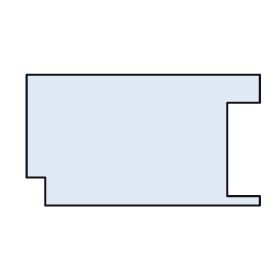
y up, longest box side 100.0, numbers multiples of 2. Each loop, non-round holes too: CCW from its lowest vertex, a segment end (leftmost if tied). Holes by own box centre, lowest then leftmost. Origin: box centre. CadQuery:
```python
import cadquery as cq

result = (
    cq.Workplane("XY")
    .moveTo(-42.0, -28.0)
    .lineTo(50.0, -28.0)
    .lineTo(50.0, -24.0)
    .lineTo(36.0, -24.0)
    .lineTo(36.0, 16.0)
    .lineTo(50.0, 16.0)
    .lineTo(50.0, 28.0)
    .lineTo(-50.0, 28.0)
    .lineTo(-50.0, -16.0)
    .lineTo(-42.0, -16.0)
    .close()
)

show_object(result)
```